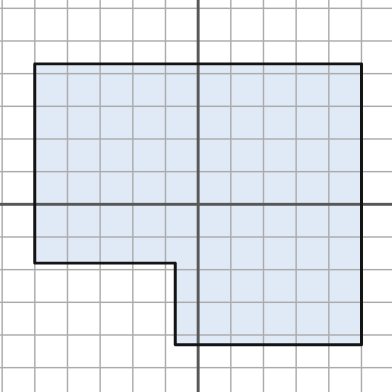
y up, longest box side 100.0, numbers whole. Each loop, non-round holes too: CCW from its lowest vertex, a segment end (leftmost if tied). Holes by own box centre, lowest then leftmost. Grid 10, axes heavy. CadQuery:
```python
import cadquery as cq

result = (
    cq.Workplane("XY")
    .moveTo(-7.0, -43.0)
    .lineTo(50.0, -43.0)
    .lineTo(50.0, 43.0)
    .lineTo(-50.0, 43.0)
    .lineTo(-50.0, -18.0)
    .lineTo(-7.0, -18.0)
    .close()
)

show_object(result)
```